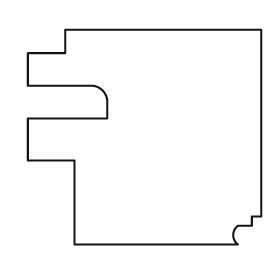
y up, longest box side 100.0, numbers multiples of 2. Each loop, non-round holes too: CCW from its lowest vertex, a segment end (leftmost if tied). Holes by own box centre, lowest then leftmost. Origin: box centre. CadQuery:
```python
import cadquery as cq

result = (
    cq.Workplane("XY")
    .moveTo(-30.0, -46.0)
    .lineTo(40.0, -46.0)
    .threePointArc((38.0, -42.0), (40.0, -38.0))
    .lineTo(46.0, -38.0)
    .lineTo(46.0, -34.0)
    .lineTo(50.0, -34.0)
    .lineTo(50.0, 46.0)
    .lineTo(-34.0, 46.0)
    .lineTo(-34.0, 36.0)
    .lineTo(-50.0, 36.0)
    .lineTo(-50.0, 22.0)
    .lineTo(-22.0, 22.0)
    .threePointArc((-18.0, 20.0), (-16.0, 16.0))
    .lineTo(-16.0, 8.0)
    .lineTo(-50.0, 8.0)
    .lineTo(-50.0, -10.0)
    .lineTo(-30.0, -10.0)
    .close()
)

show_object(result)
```